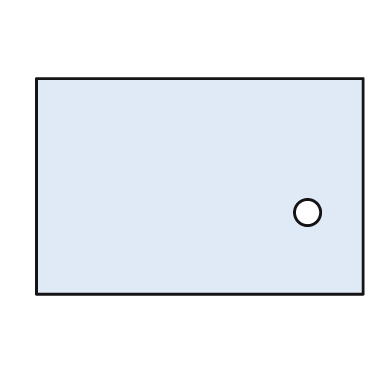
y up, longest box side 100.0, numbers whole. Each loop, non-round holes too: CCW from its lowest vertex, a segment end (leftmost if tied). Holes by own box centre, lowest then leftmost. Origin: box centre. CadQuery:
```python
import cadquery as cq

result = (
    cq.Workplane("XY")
    .moveTo(-50.0, -33.0)
    .lineTo(50.0, -33.0)
    .lineTo(50.0, 33.0)
    .lineTo(-50.0, 33.0)
    .close()
    .moveTo(33.0, -8.0)
    .circle(4.0)
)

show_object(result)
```